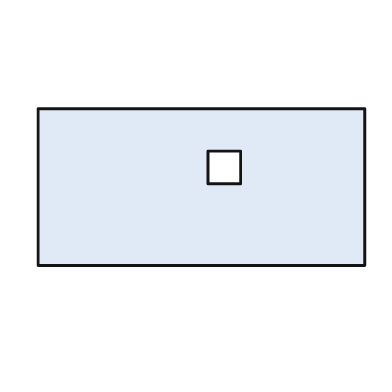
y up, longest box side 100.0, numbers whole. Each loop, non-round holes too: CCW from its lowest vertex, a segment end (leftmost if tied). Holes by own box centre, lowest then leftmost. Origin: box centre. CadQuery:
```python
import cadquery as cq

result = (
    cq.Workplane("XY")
    .moveTo(-50.0, -24.0)
    .lineTo(50.0, -24.0)
    .lineTo(50.0, 24.0)
    .lineTo(-50.0, 24.0)
    .close()
    .moveTo(2.0, 1.0)
    .lineTo(12.0, 1.0)
    .lineTo(12.0, 11.0)
    .lineTo(2.0, 11.0)
    .close()
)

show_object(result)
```